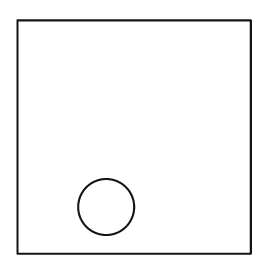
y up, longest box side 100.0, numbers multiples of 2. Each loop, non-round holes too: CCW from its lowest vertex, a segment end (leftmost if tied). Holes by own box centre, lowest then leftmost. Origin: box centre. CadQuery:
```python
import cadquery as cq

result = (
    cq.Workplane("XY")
    .moveTo(-50.0, -50.0)
    .lineTo(50.0, -50.0)
    .lineTo(50.0, 50.0)
    .lineTo(-50.0, 50.0)
    .close()
    .moveTo(-12.0, -30.0)
    .circle(12.0)
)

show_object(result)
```